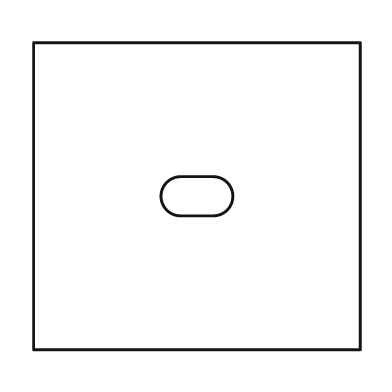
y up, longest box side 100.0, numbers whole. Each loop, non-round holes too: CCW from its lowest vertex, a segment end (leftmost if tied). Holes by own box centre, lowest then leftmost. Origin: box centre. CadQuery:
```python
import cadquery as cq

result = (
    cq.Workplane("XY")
    .moveTo(-50.0, -47.0)
    .lineTo(50.0, -47.0)
    .lineTo(50.0, 47.0)
    .lineTo(-50.0, 47.0)
    .close()
    .moveTo(-5.0, -6.0)
    .lineTo(5.0, -6.0)
    .threePointArc((11.0, 0.0), (5.0, 6.0))
    .lineTo(-5.0, 6.0)
    .threePointArc((-11.0, 0.0), (-5.0, -6.0))
    .close()
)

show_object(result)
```